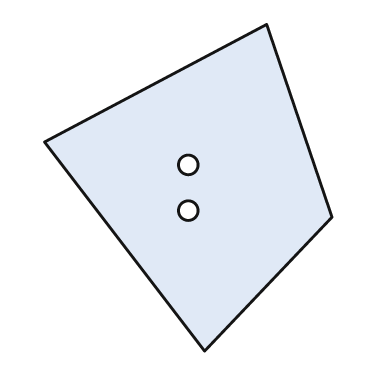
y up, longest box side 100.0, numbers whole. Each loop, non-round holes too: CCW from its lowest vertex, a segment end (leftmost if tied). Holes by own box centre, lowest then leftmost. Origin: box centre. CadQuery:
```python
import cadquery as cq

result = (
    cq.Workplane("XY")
    .moveTo(5.0, -50.0)
    .lineTo(44.0, -9.0)
    .lineTo(24.0, 50.0)
    .lineTo(-44.0, 14.0)
    .close()
    .moveTo(0.0, -7.0)
    .circle(3.0)
    .moveTo(0.0, 7.0)
    .circle(3.0)
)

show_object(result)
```